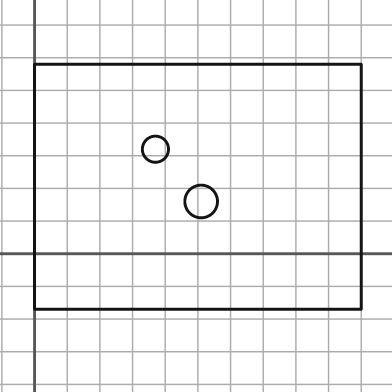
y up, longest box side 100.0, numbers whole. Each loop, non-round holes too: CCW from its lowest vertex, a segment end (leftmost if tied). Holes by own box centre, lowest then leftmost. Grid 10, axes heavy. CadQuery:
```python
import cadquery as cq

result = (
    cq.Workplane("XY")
    .moveTo(0.0, -17.0)
    .lineTo(100.0, -17.0)
    .lineTo(100.0, 58.0)
    .lineTo(0.0, 58.0)
    .close()
    .moveTo(51.0, 16.0)
    .circle(5.0)
    .moveTo(37.0, 32.0)
    .circle(4.0)
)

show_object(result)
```